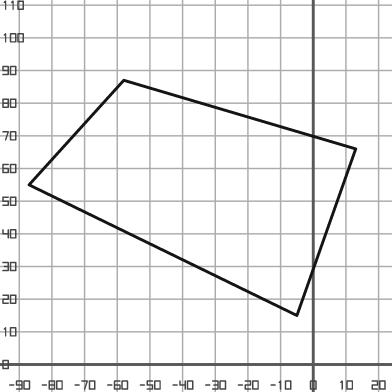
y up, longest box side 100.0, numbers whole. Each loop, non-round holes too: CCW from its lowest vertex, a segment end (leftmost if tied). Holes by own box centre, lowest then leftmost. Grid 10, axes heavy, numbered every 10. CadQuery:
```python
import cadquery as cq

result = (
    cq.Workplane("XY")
    .moveTo(-5.0, 15.0)
    .lineTo(13.0, 66.0)
    .lineTo(-58.0, 87.0)
    .lineTo(-87.0, 55.0)
    .close()
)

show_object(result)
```